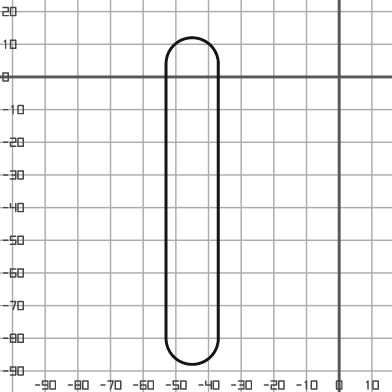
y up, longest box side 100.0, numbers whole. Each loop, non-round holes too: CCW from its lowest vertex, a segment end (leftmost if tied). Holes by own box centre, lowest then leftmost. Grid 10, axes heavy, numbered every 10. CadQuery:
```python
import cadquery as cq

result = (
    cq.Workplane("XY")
    .moveTo(-53.0, -80.0)
    .threePointArc((-45.0, -88.0), (-37.0, -80.0))
    .lineTo(-37.0, 4.0)
    .threePointArc((-45.0, 12.0), (-53.0, 4.0))
    .close()
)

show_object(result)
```